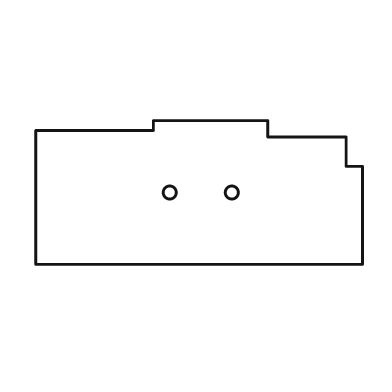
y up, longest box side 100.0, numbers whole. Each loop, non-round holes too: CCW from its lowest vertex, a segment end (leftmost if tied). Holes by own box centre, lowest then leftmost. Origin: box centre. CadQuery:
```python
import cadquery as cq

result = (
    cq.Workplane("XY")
    .moveTo(-50.0, -22.0)
    .lineTo(50.0, -22.0)
    .lineTo(50.0, 8.0)
    .lineTo(45.0, 8.0)
    .lineTo(45.0, 17.0)
    .lineTo(21.0, 17.0)
    .lineTo(21.0, 22.0)
    .lineTo(-14.0, 22.0)
    .lineTo(-14.0, 19.0)
    .lineTo(-50.0, 19.0)
    .close()
    .moveTo(-9.0, 0.0)
    .circle(2.0)
    .moveTo(10.0, 0.0)
    .circle(2.0)
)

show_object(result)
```